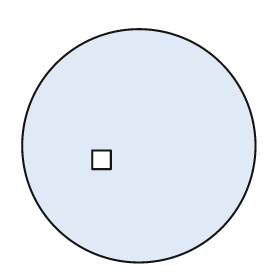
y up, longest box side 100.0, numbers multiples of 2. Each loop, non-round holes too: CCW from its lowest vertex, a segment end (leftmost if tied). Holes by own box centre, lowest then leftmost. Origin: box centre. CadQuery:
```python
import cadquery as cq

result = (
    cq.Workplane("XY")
    .moveTo(0.0, 0.0)
    .circle(50.0)
    .moveTo(-20.0, -10.0)
    .lineTo(-12.0, -10.0)
    .lineTo(-12.0, -2.0)
    .lineTo(-20.0, -2.0)
    .close()
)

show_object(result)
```